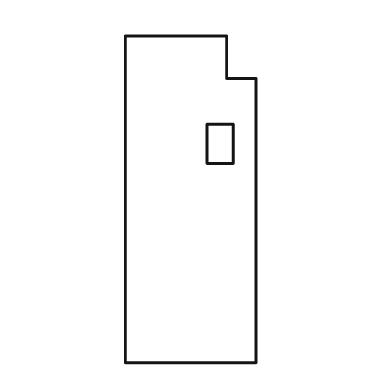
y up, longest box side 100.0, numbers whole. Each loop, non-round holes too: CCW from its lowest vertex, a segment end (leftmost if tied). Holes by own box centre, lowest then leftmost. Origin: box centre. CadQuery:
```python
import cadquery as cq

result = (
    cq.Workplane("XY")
    .moveTo(-20.0, -50.0)
    .lineTo(20.0, -50.0)
    .lineTo(20.0, 37.0)
    .lineTo(11.0, 37.0)
    .lineTo(11.0, 50.0)
    .lineTo(-20.0, 50.0)
    .close()
    .moveTo(5.0, 11.0)
    .lineTo(13.0, 11.0)
    .lineTo(13.0, 23.0)
    .lineTo(5.0, 23.0)
    .close()
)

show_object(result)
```